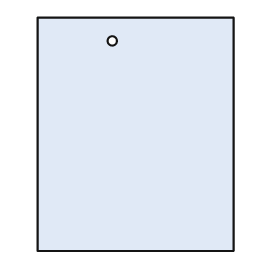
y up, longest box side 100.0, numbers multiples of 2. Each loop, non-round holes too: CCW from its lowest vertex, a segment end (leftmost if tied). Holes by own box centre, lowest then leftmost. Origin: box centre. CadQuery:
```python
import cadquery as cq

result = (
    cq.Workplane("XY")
    .moveTo(-42.0, -50.0)
    .lineTo(42.0, -50.0)
    .lineTo(42.0, 50.0)
    .lineTo(-42.0, 50.0)
    .close()
    .moveTo(-10.0, 40.0)
    .circle(2.0)
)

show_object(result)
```